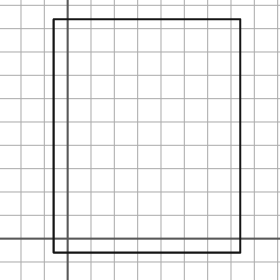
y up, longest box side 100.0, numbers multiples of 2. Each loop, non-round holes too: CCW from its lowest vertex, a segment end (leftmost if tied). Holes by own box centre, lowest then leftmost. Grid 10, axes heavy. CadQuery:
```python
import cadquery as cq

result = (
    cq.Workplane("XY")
    .moveTo(-6.0, -6.0)
    .lineTo(74.0, -6.0)
    .lineTo(74.0, 94.0)
    .lineTo(-6.0, 94.0)
    .close()
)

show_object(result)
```